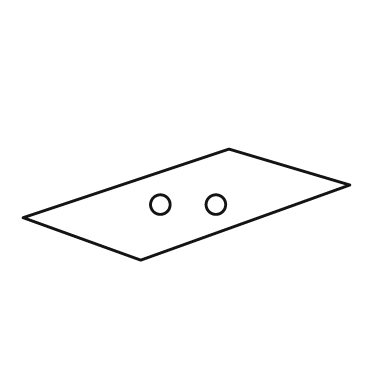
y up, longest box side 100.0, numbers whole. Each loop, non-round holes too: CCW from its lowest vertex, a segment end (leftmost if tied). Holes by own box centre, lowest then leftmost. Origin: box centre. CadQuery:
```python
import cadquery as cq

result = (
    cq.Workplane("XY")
    .moveTo(-14.0, -17.0)
    .lineTo(50.0, 6.0)
    .lineTo(13.0, 17.0)
    .lineTo(-50.0, -4.0)
    .close()
    .moveTo(-8.0, 0.0)
    .circle(3.0)
    .moveTo(9.0, 0.0)
    .circle(3.0)
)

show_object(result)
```